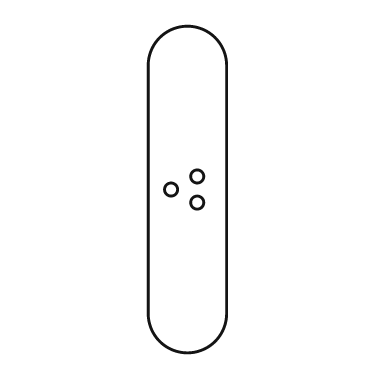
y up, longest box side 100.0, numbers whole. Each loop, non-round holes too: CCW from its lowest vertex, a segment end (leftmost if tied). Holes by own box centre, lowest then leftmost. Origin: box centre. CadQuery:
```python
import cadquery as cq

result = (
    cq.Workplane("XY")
    .moveTo(-12.0, -38.0)
    .threePointArc((0.0, -50.0), (12.0, -38.0))
    .lineTo(12.0, 38.0)
    .threePointArc((0.0, 50.0), (-12.0, 38.0))
    .close()
    .moveTo(3.0, -4.0)
    .circle(2.0)
    .moveTo(-5.0, 0.0)
    .circle(2.0)
    .moveTo(3.0, 4.0)
    .circle(2.0)
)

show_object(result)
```